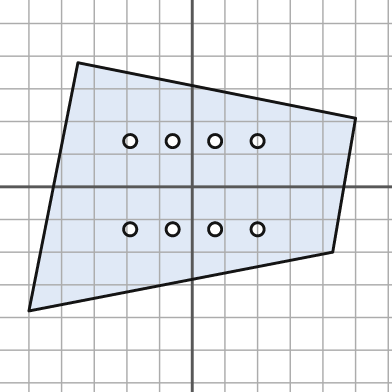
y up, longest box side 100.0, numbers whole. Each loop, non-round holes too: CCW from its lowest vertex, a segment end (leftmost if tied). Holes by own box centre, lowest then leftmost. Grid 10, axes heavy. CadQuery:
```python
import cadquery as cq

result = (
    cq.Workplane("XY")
    .moveTo(-50.0, -38.0)
    .lineTo(43.0, -20.0)
    .lineTo(50.0, 21.0)
    .lineTo(-35.0, 38.0)
    .close()
    .moveTo(-19.0, -13.0)
    .circle(2.0)
    .moveTo(-6.0, -13.0)
    .circle(2.0)
    .moveTo(7.0, -13.0)
    .circle(2.0)
    .moveTo(20.0, -13.0)
    .circle(2.0)
    .moveTo(-19.0, 14.0)
    .circle(2.0)
    .moveTo(-6.0, 14.0)
    .circle(2.0)
    .moveTo(7.0, 14.0)
    .circle(2.0)
    .moveTo(20.0, 14.0)
    .circle(2.0)
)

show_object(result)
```